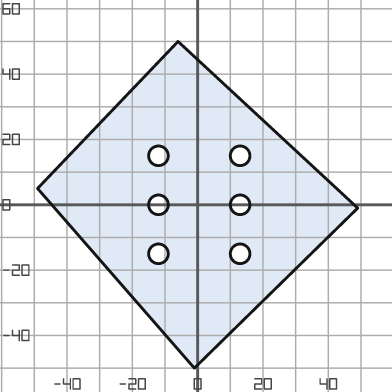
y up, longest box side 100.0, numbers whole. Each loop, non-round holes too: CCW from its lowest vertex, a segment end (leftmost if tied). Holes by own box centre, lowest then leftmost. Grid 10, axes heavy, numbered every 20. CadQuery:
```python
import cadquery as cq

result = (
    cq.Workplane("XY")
    .moveTo(-1.0, -50.0)
    .lineTo(49.0, -1.0)
    .lineTo(-6.0, 50.0)
    .lineTo(-49.0, 5.0)
    .close()
    .moveTo(-12.0, -15.0)
    .circle(3.0)
    .moveTo(13.0, -15.0)
    .circle(3.0)
    .moveTo(-12.0, 0.0)
    .circle(3.0)
    .moveTo(13.0, 0.0)
    .circle(3.0)
    .moveTo(-12.0, 15.0)
    .circle(3.0)
    .moveTo(13.0, 15.0)
    .circle(3.0)
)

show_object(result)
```